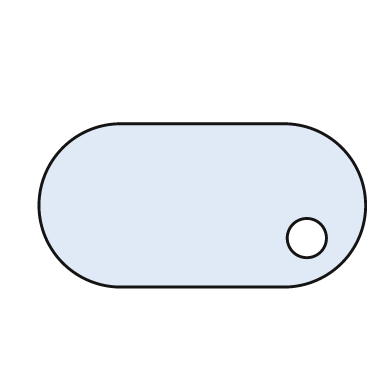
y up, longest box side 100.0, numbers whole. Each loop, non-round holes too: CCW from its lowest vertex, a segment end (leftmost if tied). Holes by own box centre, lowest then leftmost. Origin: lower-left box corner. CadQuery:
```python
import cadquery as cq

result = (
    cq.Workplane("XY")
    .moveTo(25.0, 0.0)
    .lineTo(75.0, 0.0)
    .threePointArc((100.0, 25.0), (75.0, 50.0))
    .lineTo(25.0, 50.0)
    .threePointArc((0.0, 25.0), (25.0, 0.0))
    .close()
    .moveTo(82.0, 15.0)
    .circle(6.0)
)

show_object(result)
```